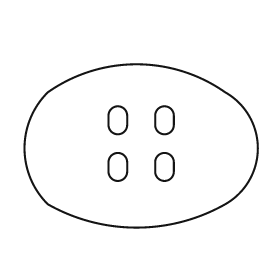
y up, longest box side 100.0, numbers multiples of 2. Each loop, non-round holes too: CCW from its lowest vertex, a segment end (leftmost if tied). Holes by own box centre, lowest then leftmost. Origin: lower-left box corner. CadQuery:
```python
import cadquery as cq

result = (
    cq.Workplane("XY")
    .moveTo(10.0, 10.0)
    .threePointArc((48.0, 0.0), (86.0, 10.0))
    .threePointArc((100.0, 34.0), (86.0, 58.0))
    .threePointArc((48.0, 70.0), (10.0, 58.0))
    .threePointArc((0.0, 34.0), (10.0, 10.0))
    .close()
    .moveTo(36.0, 24.0)
    .threePointArc((40.0, 20.0), (44.0, 24.0))
    .lineTo(44.0, 28.0)
    .threePointArc((40.0, 32.0), (36.0, 28.0))
    .close()
    .moveTo(56.0, 24.0)
    .threePointArc((60.0, 20.0), (64.0, 24.0))
    .lineTo(64.0, 28.0)
    .threePointArc((60.0, 32.0), (56.0, 28.0))
    .close()
    .moveTo(36.0, 44.0)
    .threePointArc((40.0, 40.0), (44.0, 44.0))
    .lineTo(44.0, 48.0)
    .threePointArc((40.0, 52.0), (36.0, 48.0))
    .close()
    .moveTo(56.0, 44.0)
    .threePointArc((60.0, 40.0), (64.0, 44.0))
    .lineTo(64.0, 48.0)
    .threePointArc((60.0, 52.0), (56.0, 48.0))
    .close()
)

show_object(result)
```